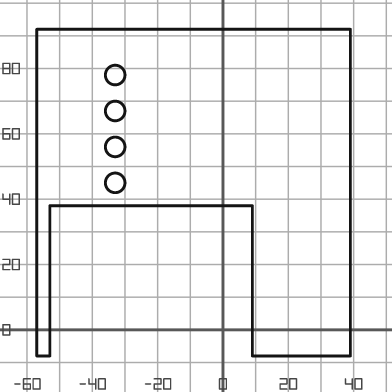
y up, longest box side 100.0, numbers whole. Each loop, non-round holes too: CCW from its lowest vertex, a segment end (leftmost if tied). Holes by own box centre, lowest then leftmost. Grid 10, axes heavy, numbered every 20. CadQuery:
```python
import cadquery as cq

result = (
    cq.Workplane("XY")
    .moveTo(-57.0, -8.0)
    .lineTo(-53.0, -8.0)
    .lineTo(-53.0, 38.0)
    .lineTo(9.0, 38.0)
    .lineTo(9.0, -8.0)
    .lineTo(39.0, -8.0)
    .lineTo(39.0, 92.0)
    .lineTo(-57.0, 92.0)
    .close()
    .moveTo(-33.0, 45.0)
    .circle(3.0)
    .moveTo(-33.0, 56.0)
    .circle(3.0)
    .moveTo(-33.0, 67.0)
    .circle(3.0)
    .moveTo(-33.0, 78.0)
    .circle(3.0)
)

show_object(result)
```